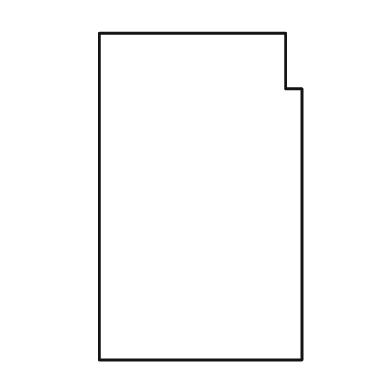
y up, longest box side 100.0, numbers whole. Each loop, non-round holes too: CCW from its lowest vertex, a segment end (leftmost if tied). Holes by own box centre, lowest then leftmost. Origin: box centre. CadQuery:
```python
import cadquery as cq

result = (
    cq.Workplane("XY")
    .moveTo(-31.0, -50.0)
    .lineTo(31.0, -50.0)
    .lineTo(31.0, 33.0)
    .lineTo(26.0, 33.0)
    .lineTo(26.0, 50.0)
    .lineTo(-31.0, 50.0)
    .close()
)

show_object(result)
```